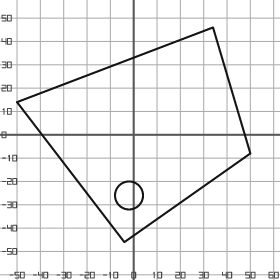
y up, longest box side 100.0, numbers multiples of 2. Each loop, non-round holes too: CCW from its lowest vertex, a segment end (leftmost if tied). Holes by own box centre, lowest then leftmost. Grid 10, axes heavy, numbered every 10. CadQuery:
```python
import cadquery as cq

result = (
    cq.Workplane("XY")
    .moveTo(-4.0, -46.0)
    .lineTo(50.0, -8.0)
    .lineTo(34.0, 46.0)
    .lineTo(-50.0, 14.0)
    .close()
    .moveTo(-2.0, -26.0)
    .circle(6.0)
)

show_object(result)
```